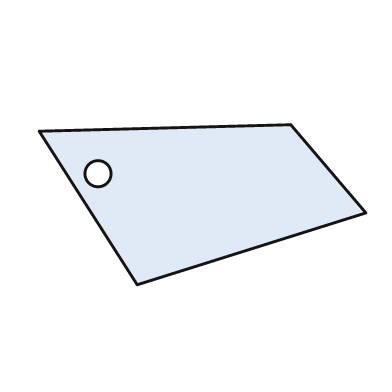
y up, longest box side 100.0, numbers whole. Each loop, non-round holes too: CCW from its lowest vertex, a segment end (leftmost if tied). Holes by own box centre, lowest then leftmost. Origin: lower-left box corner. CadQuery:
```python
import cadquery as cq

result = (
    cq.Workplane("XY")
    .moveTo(30.0, 0.0)
    .lineTo(100.0, 22.0)
    .lineTo(77.0, 49.0)
    .lineTo(0.0, 47.0)
    .close()
    .moveTo(18.0, 34.0)
    .circle(4.0)
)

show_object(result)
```